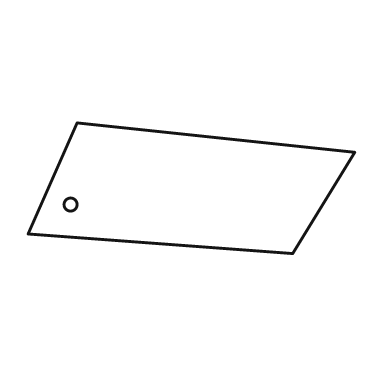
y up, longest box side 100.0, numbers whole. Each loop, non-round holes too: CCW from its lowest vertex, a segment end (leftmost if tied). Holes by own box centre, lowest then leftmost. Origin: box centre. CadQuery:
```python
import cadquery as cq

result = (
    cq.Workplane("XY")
    .moveTo(31.0, -20.0)
    .lineTo(50.0, 11.0)
    .lineTo(-35.0, 20.0)
    .lineTo(-50.0, -14.0)
    .close()
    .moveTo(-37.0, -5.0)
    .circle(2.0)
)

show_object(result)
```